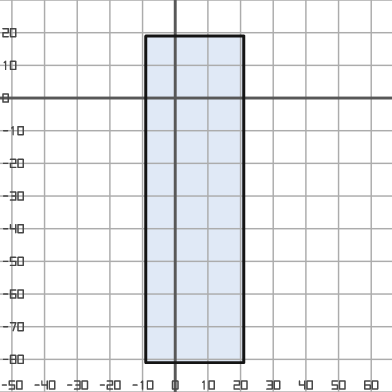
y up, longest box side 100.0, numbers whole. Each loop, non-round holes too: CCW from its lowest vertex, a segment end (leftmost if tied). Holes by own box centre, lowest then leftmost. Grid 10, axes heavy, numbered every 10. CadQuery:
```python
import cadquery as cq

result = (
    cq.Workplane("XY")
    .moveTo(-9.0, -81.0)
    .lineTo(21.0, -81.0)
    .lineTo(21.0, 19.0)
    .lineTo(-9.0, 19.0)
    .close()
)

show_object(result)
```